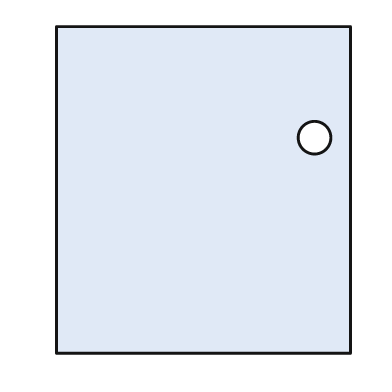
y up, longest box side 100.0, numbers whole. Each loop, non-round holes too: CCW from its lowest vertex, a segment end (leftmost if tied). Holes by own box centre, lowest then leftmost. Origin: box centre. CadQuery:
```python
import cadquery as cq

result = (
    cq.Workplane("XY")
    .moveTo(-45.0, -50.0)
    .lineTo(45.0, -50.0)
    .lineTo(45.0, 50.0)
    .lineTo(-45.0, 50.0)
    .close()
    .moveTo(34.0, 16.0)
    .circle(5.0)
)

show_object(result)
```